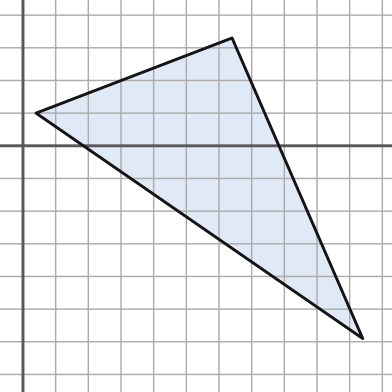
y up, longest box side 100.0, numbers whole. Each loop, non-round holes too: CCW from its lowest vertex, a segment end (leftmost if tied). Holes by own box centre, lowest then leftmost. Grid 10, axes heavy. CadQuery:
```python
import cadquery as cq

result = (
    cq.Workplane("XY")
    .moveTo(104.0, -59.0)
    .lineTo(64.0, 33.0)
    .lineTo(4.0, 10.0)
    .close()
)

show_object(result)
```